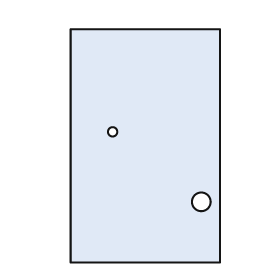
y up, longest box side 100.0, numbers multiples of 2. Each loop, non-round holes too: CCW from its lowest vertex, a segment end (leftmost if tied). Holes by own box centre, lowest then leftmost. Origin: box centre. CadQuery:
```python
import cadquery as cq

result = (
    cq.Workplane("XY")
    .moveTo(-32.0, -50.0)
    .lineTo(32.0, -50.0)
    .lineTo(32.0, 50.0)
    .lineTo(-32.0, 50.0)
    .close()
    .moveTo(24.0, -24.0)
    .circle(4.0)
    .moveTo(-14.0, 6.0)
    .circle(2.0)
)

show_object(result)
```